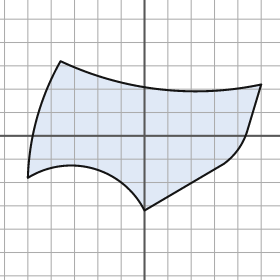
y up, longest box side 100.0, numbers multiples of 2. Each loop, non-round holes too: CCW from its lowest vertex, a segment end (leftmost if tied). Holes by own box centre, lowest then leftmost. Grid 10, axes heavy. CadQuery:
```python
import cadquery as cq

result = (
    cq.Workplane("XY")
    .moveTo(0.0, -32.0)
    .lineTo(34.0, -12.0)
    .threePointArc((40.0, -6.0), (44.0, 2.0))
    .lineTo(50.0, 22.0)
    .threePointArc((6.0, 20.0), (-36.0, 32.0))
    .threePointArc((-46.0, 8.0), (-50.0, -18.0))
    .threePointArc((-22.0, -14.0), (0.0, -32.0))
    .close()
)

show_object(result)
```